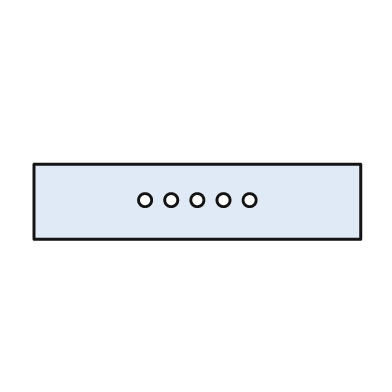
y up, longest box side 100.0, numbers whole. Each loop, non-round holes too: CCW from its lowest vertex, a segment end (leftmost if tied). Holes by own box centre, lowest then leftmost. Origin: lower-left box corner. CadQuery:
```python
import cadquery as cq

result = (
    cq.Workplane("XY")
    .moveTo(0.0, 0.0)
    .lineTo(100.0, 0.0)
    .lineTo(100.0, 23.0)
    .lineTo(0.0, 23.0)
    .close()
    .moveTo(34.0, 12.0)
    .circle(2.0)
    .moveTo(42.0, 12.0)
    .circle(2.0)
    .moveTo(50.0, 12.0)
    .circle(2.0)
    .moveTo(58.0, 12.0)
    .circle(2.0)
    .moveTo(66.0, 12.0)
    .circle(2.0)
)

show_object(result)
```